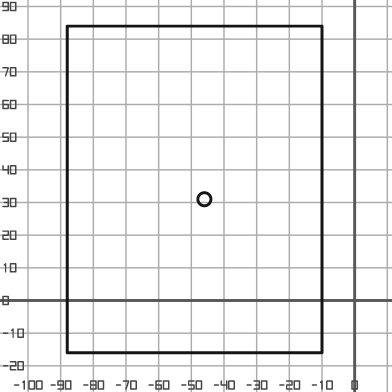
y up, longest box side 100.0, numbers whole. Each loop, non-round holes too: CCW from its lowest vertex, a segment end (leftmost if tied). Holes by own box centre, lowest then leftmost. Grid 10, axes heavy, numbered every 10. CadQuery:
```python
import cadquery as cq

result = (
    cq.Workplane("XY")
    .moveTo(-88.0, -16.0)
    .lineTo(-10.0, -16.0)
    .lineTo(-10.0, 84.0)
    .lineTo(-88.0, 84.0)
    .close()
    .moveTo(-46.0, 31.0)
    .circle(2.0)
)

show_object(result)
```